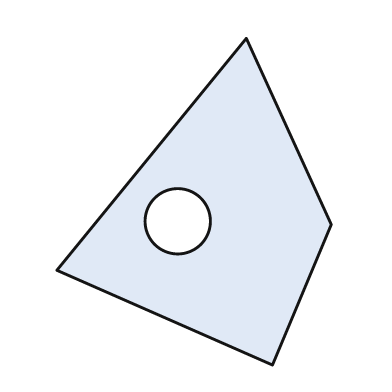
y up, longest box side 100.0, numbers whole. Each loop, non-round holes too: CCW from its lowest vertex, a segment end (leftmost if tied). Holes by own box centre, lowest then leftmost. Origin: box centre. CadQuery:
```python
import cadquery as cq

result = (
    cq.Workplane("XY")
    .moveTo(24.0, -50.0)
    .lineTo(42.0, -7.0)
    .lineTo(16.0, 50.0)
    .lineTo(-42.0, -21.0)
    .close()
    .moveTo(-5.0, -6.0)
    .circle(10.0)
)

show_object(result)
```